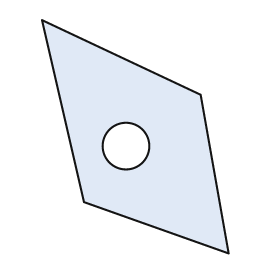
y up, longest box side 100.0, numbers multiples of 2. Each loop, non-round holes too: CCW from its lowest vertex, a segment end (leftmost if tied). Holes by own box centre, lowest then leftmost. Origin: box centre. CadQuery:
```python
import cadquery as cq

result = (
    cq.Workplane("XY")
    .moveTo(40.0, -50.0)
    .lineTo(28.0, 18.0)
    .lineTo(-40.0, 50.0)
    .lineTo(-22.0, -28.0)
    .close()
    .moveTo(-4.0, -4.0)
    .circle(10.0)
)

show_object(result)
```